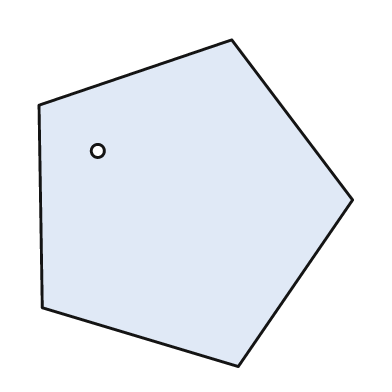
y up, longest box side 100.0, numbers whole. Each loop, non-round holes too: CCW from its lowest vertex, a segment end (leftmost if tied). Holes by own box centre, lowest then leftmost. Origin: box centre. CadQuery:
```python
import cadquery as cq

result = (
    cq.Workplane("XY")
    .moveTo(13.0, -50.0)
    .lineTo(48.0, 1.0)
    .lineTo(11.0, 50.0)
    .lineTo(-48.0, 30.0)
    .lineTo(-47.0, -32.0)
    .close()
    .moveTo(-30.0, 16.0)
    .circle(2.0)
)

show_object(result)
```